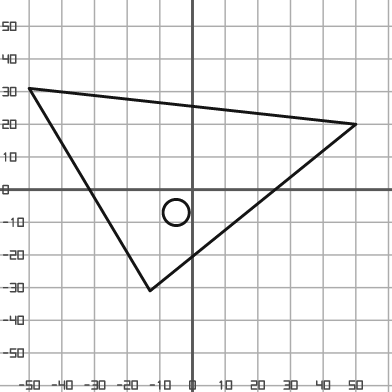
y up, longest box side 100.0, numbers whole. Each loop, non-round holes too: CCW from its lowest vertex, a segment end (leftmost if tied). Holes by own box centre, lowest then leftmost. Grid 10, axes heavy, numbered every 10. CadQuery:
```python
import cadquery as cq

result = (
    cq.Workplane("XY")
    .moveTo(-13.0, -31.0)
    .lineTo(50.0, 20.0)
    .lineTo(-50.0, 31.0)
    .close()
    .moveTo(-5.0, -7.0)
    .circle(4.0)
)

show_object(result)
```